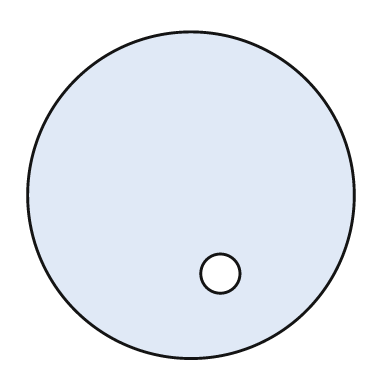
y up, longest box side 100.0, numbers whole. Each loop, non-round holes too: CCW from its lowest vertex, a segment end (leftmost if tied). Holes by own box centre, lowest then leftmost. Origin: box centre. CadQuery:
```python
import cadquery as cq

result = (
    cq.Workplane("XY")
    .moveTo(0.0, 0.0)
    .circle(50.0)
    .moveTo(9.0, -24.0)
    .circle(6.0)
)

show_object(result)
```